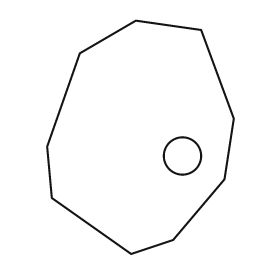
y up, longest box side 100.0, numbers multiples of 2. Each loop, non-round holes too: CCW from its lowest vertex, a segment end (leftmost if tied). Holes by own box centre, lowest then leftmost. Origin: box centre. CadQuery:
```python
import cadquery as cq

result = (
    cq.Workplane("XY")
    .moveTo(-4.0, -50.0)
    .lineTo(14.0, -44.0)
    .lineTo(36.0, -18.0)
    .lineTo(40.0, 8.0)
    .lineTo(26.0, 46.0)
    .lineTo(-2.0, 50.0)
    .lineTo(-26.0, 36.0)
    .lineTo(-40.0, -4.0)
    .lineTo(-38.0, -26.0)
    .close()
    .moveTo(18.0, -8.0)
    .circle(8.0)
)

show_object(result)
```